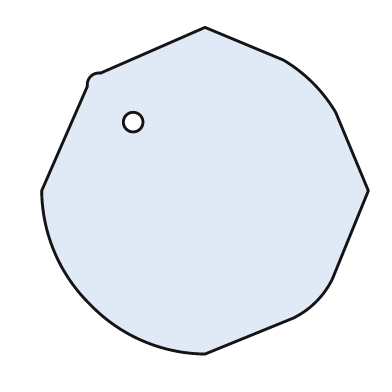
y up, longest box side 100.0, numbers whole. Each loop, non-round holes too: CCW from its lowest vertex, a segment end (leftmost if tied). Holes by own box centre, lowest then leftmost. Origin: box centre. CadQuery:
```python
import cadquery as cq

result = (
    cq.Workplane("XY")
    .moveTo(0.0, -50.0)
    .lineTo(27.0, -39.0)
    .threePointArc((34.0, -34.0), (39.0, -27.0))
    .lineTo(50.0, 0.0)
    .lineTo(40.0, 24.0)
    .threePointArc((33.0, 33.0), (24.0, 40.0))
    .lineTo(0.0, 50.0)
    .lineTo(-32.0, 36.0)
    .threePointArc((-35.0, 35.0), (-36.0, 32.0))
    .lineTo(-50.0, 0.0)
    .threePointArc((-46.0, -19.0), (-35.0, -35.0))
    .threePointArc((-19.0, -46.0), (0.0, -50.0))
    .close()
    .moveTo(-22.0, 21.0)
    .circle(3.0)
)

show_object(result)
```